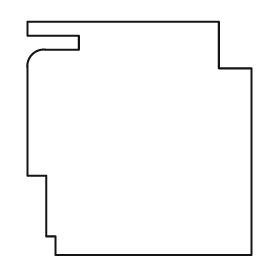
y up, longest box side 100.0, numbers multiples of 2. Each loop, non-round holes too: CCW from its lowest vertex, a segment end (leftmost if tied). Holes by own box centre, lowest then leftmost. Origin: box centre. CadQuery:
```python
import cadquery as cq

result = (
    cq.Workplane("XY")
    .moveTo(-36.0, -50.0)
    .lineTo(48.0, -50.0)
    .lineTo(48.0, 30.0)
    .lineTo(34.0, 30.0)
    .lineTo(34.0, 50.0)
    .lineTo(-48.0, 50.0)
    .lineTo(-48.0, 44.0)
    .lineTo(-26.0, 44.0)
    .lineTo(-26.0, 38.0)
    .lineTo(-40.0, 38.0)
    .threePointArc((-46.0, 36.0), (-48.0, 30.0))
    .lineTo(-48.0, -16.0)
    .lineTo(-40.0, -16.0)
    .lineTo(-40.0, -42.0)
    .lineTo(-36.0, -42.0)
    .close()
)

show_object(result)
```